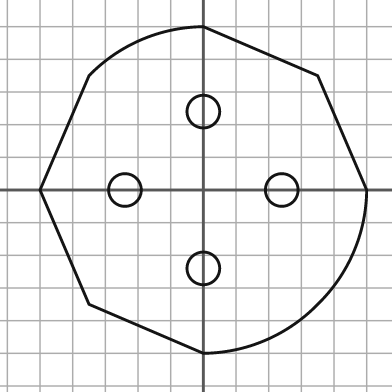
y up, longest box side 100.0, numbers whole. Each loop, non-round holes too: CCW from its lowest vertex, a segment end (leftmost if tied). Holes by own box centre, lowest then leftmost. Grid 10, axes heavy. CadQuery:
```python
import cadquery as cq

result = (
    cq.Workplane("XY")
    .moveTo(0.0, -50.0)
    .threePointArc((19.0, -46.0), (35.0, -35.0))
    .threePointArc((46.0, -19.0), (50.0, 0.0))
    .lineTo(35.0, 35.0)
    .lineTo(0.0, 50.0)
    .threePointArc((-19.0, 46.0), (-35.0, 35.0))
    .lineTo(-50.0, 0.0)
    .lineTo(-35.0, -35.0)
    .close()
    .moveTo(0.0, -24.0)
    .circle(5.0)
    .moveTo(-24.0, 0.0)
    .circle(5.0)
    .moveTo(24.0, 0.0)
    .circle(5.0)
    .moveTo(0.0, 24.0)
    .circle(5.0)
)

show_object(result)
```